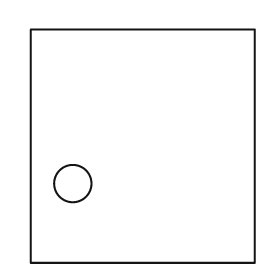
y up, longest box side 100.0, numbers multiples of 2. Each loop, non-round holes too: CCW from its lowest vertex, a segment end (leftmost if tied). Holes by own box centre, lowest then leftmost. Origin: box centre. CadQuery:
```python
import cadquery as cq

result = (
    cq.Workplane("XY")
    .moveTo(-48.0, -50.0)
    .lineTo(48.0, -50.0)
    .lineTo(48.0, 50.0)
    .lineTo(-48.0, 50.0)
    .close()
    .moveTo(-30.0, -16.0)
    .circle(8.0)
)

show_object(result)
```